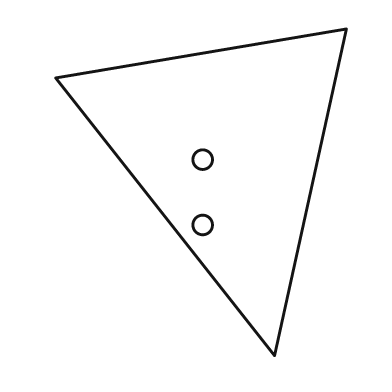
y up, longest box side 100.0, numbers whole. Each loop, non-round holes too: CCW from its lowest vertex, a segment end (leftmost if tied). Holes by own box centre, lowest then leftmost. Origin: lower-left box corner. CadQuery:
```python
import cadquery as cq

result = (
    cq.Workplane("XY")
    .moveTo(67.0, 0.0)
    .lineTo(89.0, 100.0)
    .lineTo(0.0, 85.0)
    .close()
    .moveTo(45.0, 40.0)
    .circle(3.0)
    .moveTo(45.0, 60.0)
    .circle(3.0)
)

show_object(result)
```